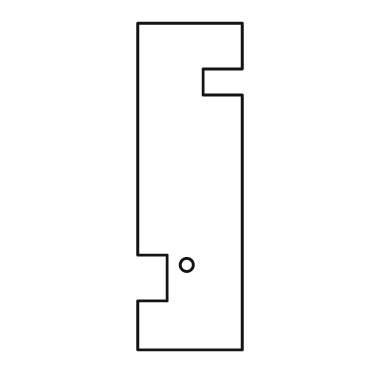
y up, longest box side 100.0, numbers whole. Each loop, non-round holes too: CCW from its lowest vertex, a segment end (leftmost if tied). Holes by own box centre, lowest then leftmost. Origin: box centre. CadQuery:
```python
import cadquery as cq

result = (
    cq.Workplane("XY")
    .moveTo(-16.0, -50.0)
    .lineTo(16.0, -50.0)
    .lineTo(16.0, 28.0)
    .lineTo(4.0, 28.0)
    .lineTo(4.0, 36.0)
    .lineTo(16.0, 36.0)
    .lineTo(16.0, 50.0)
    .lineTo(-16.0, 50.0)
    .lineTo(-16.0, -21.0)
    .lineTo(-7.0, -21.0)
    .lineTo(-7.0, -35.0)
    .lineTo(-16.0, -35.0)
    .close()
    .moveTo(-1.0, -24.0)
    .circle(2.0)
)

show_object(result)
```